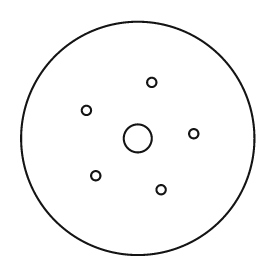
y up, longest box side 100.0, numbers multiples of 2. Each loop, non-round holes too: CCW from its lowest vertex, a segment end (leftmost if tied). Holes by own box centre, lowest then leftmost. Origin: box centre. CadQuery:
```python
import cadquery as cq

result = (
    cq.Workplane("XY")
    .moveTo(0.0, 0.0)
    .circle(50.0)
    .moveTo(10.0, -22.0)
    .circle(2.0)
    .moveTo(-18.0, -16.0)
    .circle(2.0)
    .moveTo(0.0, 0.0)
    .circle(6.0)
    .moveTo(24.0, 2.0)
    .circle(2.0)
    .moveTo(-22.0, 12.0)
    .circle(2.0)
    .moveTo(6.0, 24.0)
    .circle(2.0)
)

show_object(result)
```